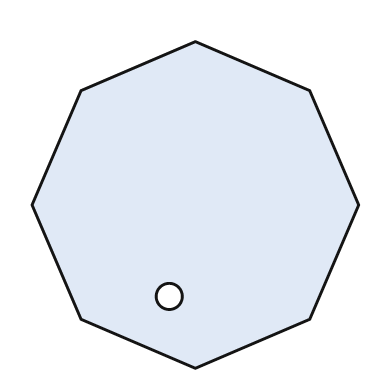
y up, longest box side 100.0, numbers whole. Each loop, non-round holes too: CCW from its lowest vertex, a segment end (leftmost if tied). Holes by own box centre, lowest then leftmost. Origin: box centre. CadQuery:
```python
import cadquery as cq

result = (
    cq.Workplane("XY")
    .moveTo(0.0, -50.0)
    .lineTo(35.0, -35.0)
    .lineTo(50.0, 0.0)
    .lineTo(35.0, 35.0)
    .lineTo(0.0, 50.0)
    .lineTo(-35.0, 35.0)
    .lineTo(-50.0, 0.0)
    .lineTo(-35.0, -35.0)
    .close()
    .moveTo(-8.0, -28.0)
    .circle(4.0)
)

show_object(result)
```